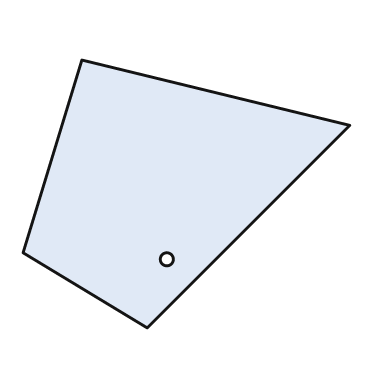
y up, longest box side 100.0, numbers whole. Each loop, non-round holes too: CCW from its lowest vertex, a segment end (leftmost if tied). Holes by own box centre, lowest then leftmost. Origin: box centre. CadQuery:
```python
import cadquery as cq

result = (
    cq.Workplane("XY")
    .moveTo(-12.0, -41.0)
    .lineTo(50.0, 21.0)
    .lineTo(-32.0, 41.0)
    .lineTo(-50.0, -18.0)
    .close()
    .moveTo(-6.0, -20.0)
    .circle(2.0)
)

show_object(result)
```